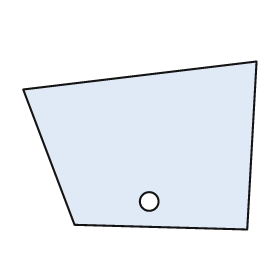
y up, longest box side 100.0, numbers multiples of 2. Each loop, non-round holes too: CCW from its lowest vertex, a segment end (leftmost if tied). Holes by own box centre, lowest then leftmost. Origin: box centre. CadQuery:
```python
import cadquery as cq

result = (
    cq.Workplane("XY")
    .moveTo(46.0, -36.0)
    .lineTo(50.0, 36.0)
    .lineTo(-50.0, 24.0)
    .lineTo(-28.0, -34.0)
    .close()
    .moveTo(4.0, -24.0)
    .circle(4.0)
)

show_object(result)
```